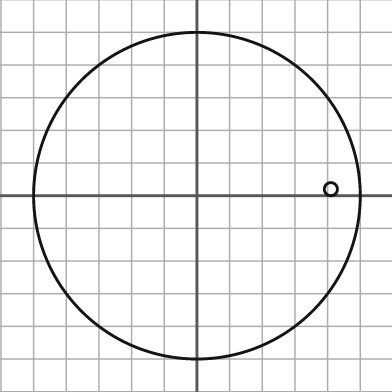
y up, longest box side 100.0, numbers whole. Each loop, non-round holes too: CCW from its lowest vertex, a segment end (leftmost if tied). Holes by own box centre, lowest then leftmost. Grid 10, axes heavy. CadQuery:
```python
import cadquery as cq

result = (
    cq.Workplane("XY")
    .moveTo(0.0, 0.0)
    .circle(50.0)
    .moveTo(41.0, 2.0)
    .circle(2.0)
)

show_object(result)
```